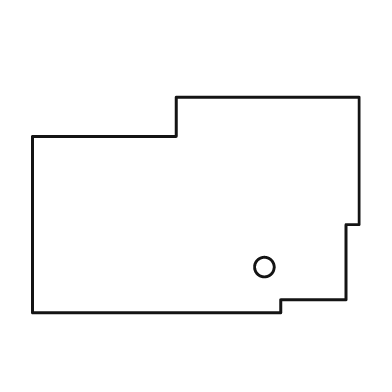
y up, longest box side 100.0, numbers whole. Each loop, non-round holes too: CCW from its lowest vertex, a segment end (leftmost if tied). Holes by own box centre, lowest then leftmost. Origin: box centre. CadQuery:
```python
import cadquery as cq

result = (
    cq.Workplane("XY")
    .moveTo(-50.0, -33.0)
    .lineTo(26.0, -33.0)
    .lineTo(26.0, -29.0)
    .lineTo(46.0, -29.0)
    .lineTo(46.0, -6.0)
    .lineTo(50.0, -6.0)
    .lineTo(50.0, 33.0)
    .lineTo(-6.0, 33.0)
    .lineTo(-6.0, 21.0)
    .lineTo(-50.0, 21.0)
    .close()
    .moveTo(21.0, -19.0)
    .circle(3.0)
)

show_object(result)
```